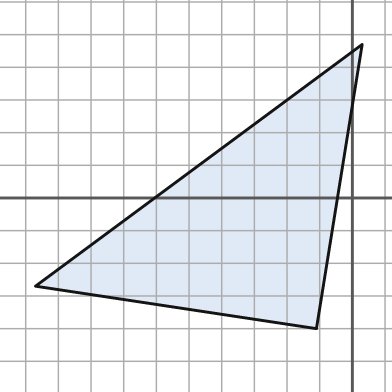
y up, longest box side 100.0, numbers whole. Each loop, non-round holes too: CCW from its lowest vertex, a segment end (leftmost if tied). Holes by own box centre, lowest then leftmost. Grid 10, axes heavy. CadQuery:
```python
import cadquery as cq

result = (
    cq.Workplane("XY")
    .moveTo(-11.0, -40.0)
    .lineTo(3.0, 47.0)
    .lineTo(-97.0, -27.0)
    .close()
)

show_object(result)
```